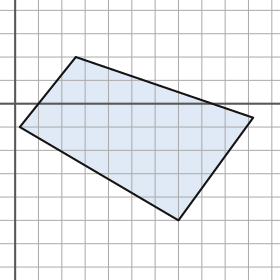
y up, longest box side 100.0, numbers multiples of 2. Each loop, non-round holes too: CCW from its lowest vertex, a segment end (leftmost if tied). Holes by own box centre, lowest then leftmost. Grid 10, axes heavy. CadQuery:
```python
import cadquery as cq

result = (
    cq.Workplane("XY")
    .moveTo(70.0, -50.0)
    .lineTo(102.0, -6.0)
    .lineTo(26.0, 20.0)
    .lineTo(2.0, -10.0)
    .close()
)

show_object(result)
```